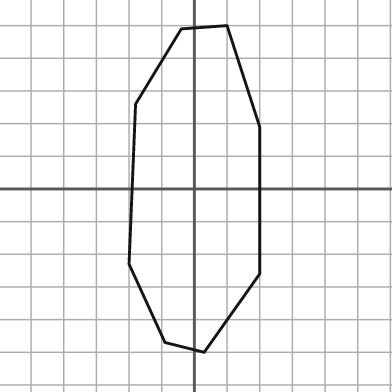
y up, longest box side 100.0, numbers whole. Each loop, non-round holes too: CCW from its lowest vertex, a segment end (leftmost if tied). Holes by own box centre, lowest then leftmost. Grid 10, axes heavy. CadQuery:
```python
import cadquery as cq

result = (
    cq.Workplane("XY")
    .moveTo(3.0, -50.0)
    .lineTo(20.0, -26.0)
    .lineTo(20.0, 19.0)
    .lineTo(10.0, 50.0)
    .lineTo(-4.0, 49.0)
    .lineTo(-18.0, 26.0)
    .lineTo(-20.0, -23.0)
    .lineTo(-9.0, -47.0)
    .close()
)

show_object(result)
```